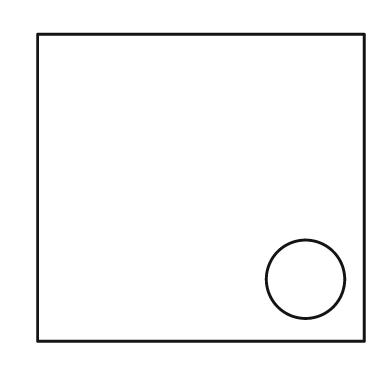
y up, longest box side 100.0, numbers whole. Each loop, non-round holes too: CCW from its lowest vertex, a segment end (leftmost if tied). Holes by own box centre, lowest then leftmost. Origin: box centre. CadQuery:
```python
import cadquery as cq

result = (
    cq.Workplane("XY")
    .moveTo(-50.0, -47.0)
    .lineTo(50.0, -47.0)
    .lineTo(50.0, 47.0)
    .lineTo(-50.0, 47.0)
    .close()
    .moveTo(32.0, -28.0)
    .circle(12.0)
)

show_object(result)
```